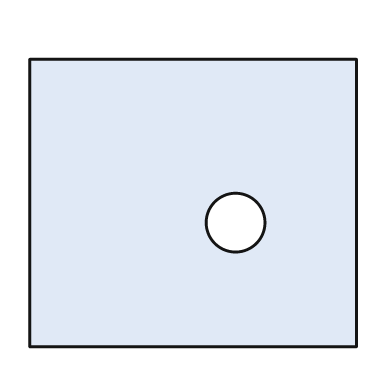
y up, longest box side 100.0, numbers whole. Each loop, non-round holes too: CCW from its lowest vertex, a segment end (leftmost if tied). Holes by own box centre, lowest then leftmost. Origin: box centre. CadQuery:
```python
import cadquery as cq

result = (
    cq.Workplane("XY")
    .moveTo(-50.0, -44.0)
    .lineTo(50.0, -44.0)
    .lineTo(50.0, 44.0)
    .lineTo(-50.0, 44.0)
    .close()
    .moveTo(13.0, -6.0)
    .circle(9.0)
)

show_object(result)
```